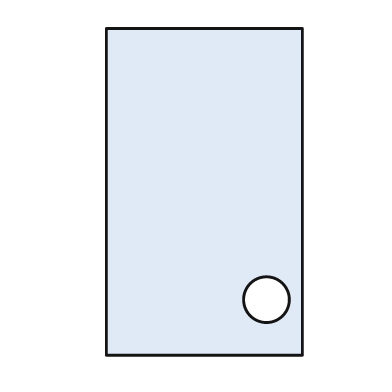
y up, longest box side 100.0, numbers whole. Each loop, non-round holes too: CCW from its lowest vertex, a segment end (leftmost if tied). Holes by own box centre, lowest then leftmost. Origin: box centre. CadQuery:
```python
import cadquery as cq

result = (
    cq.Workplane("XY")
    .moveTo(-30.0, -50.0)
    .lineTo(30.0, -50.0)
    .lineTo(30.0, 50.0)
    .lineTo(-30.0, 50.0)
    .close()
    .moveTo(19.0, -33.0)
    .circle(7.0)
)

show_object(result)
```